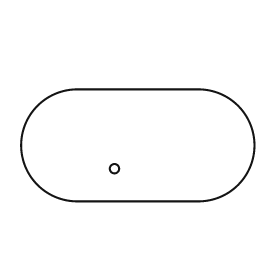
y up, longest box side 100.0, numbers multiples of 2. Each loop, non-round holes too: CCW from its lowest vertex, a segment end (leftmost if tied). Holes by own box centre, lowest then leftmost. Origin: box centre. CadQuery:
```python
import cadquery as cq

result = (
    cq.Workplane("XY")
    .moveTo(-26.0, -24.0)
    .lineTo(26.0, -24.0)
    .threePointArc((50.0, 0.0), (26.0, 24.0))
    .lineTo(-26.0, 24.0)
    .threePointArc((-50.0, 0.0), (-26.0, -24.0))
    .close()
    .moveTo(-10.0, -10.0)
    .circle(2.0)
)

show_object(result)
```